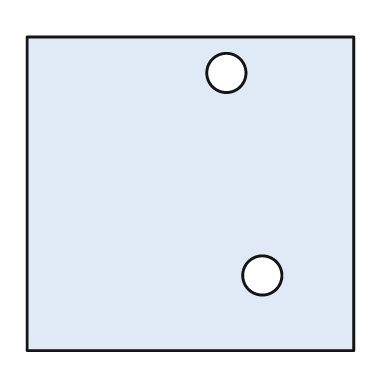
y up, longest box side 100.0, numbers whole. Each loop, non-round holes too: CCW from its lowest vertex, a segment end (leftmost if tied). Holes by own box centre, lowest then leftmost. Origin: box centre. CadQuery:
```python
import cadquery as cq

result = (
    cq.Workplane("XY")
    .moveTo(-50.0, -48.0)
    .lineTo(50.0, -48.0)
    .lineTo(50.0, 48.0)
    .lineTo(-50.0, 48.0)
    .close()
    .moveTo(22.0, -25.0)
    .circle(6.0)
    .moveTo(11.0, 37.0)
    .circle(6.0)
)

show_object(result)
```